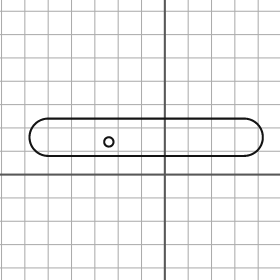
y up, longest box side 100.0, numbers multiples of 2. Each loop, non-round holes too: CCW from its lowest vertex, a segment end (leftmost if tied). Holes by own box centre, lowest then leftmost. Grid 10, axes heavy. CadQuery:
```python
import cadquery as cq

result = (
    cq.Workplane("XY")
    .moveTo(-50.0, 8.0)
    .lineTo(34.0, 8.0)
    .threePointArc((42.0, 16.0), (34.0, 24.0))
    .lineTo(-50.0, 24.0)
    .threePointArc((-58.0, 16.0), (-50.0, 8.0))
    .close()
    .moveTo(-24.0, 14.0)
    .circle(2.0)
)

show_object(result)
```